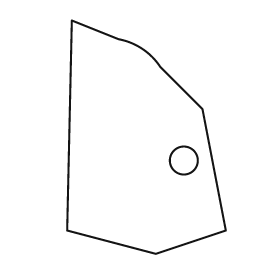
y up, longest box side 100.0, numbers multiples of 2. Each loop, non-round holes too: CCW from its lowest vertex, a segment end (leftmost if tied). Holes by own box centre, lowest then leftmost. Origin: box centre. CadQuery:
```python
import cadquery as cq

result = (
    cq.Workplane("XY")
    .moveTo(4.0, -50.0)
    .lineTo(34.0, -40.0)
    .lineTo(24.0, 12.0)
    .lineTo(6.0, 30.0)
    .threePointArc((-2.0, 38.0), (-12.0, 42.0))
    .lineTo(-32.0, 50.0)
    .lineTo(-34.0, -40.0)
    .close()
    .moveTo(16.0, -10.0)
    .circle(6.0)
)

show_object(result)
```